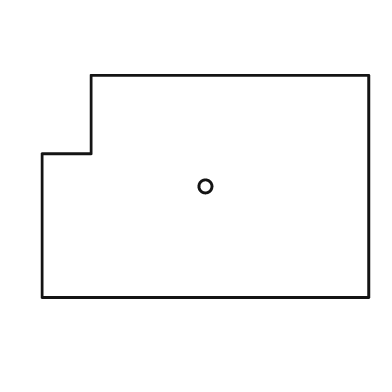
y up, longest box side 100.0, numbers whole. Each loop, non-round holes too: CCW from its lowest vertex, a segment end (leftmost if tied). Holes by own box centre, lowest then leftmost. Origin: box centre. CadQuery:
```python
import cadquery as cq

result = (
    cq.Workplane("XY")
    .moveTo(-50.0, -34.0)
    .lineTo(50.0, -34.0)
    .lineTo(50.0, 34.0)
    .lineTo(-35.0, 34.0)
    .lineTo(-35.0, 10.0)
    .lineTo(-50.0, 10.0)
    .close()
    .moveTo(0.0, 0.0)
    .circle(2.0)
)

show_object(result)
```